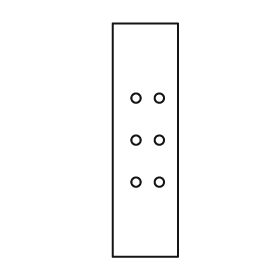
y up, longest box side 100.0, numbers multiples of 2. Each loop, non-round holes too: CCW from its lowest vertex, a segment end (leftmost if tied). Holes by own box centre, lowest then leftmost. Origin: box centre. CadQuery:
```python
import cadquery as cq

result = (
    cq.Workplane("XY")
    .moveTo(-14.0, -50.0)
    .lineTo(14.0, -50.0)
    .lineTo(14.0, 50.0)
    .lineTo(-14.0, 50.0)
    .close()
    .moveTo(-4.0, -18.0)
    .circle(2.0)
    .moveTo(6.0, -18.0)
    .circle(2.0)
    .moveTo(-4.0, 0.0)
    .circle(2.0)
    .moveTo(6.0, 0.0)
    .circle(2.0)
    .moveTo(-4.0, 18.0)
    .circle(2.0)
    .moveTo(6.0, 18.0)
    .circle(2.0)
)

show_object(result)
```